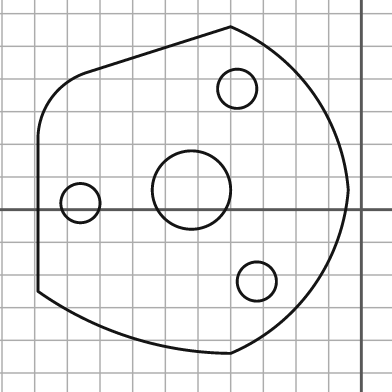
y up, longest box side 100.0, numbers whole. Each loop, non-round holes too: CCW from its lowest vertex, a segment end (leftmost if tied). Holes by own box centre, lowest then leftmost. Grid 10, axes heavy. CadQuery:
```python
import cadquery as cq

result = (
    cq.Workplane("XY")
    .moveTo(-40.0, -44.0)
    .threePointArc((-15.0, -24.0), (-4.0, 6.0))
    .threePointArc((-15.0, 36.0), (-40.0, 56.0))
    .lineTo(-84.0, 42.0)
    .threePointArc((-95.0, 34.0), (-99.0, 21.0))
    .lineTo(-99.0, -25.0)
    .threePointArc((-71.0, -39.0), (-40.0, -44.0))
    .close()
    .moveTo(-32.0, -22.0)
    .circle(6.0)
    .moveTo(-86.0, 2.0)
    .circle(6.0)
    .moveTo(-52.0, 6.0)
    .circle(12.0)
    .moveTo(-38.0, 37.0)
    .circle(6.0)
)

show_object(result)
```